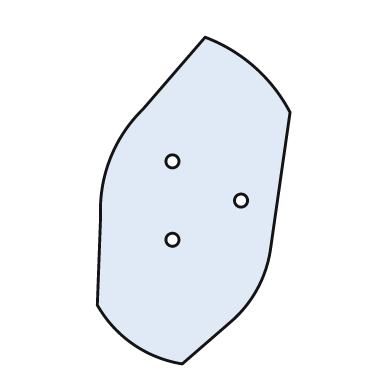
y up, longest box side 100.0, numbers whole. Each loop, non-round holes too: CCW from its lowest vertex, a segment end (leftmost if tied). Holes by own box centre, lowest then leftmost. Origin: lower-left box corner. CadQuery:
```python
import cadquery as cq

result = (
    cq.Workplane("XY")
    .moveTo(26.0, 0.0)
    .lineTo(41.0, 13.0)
    .threePointArc((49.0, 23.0), (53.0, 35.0))
    .lineTo(59.0, 77.0)
    .threePointArc((48.0, 91.0), (33.0, 100.0))
    .lineTo(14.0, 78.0)
    .threePointArc((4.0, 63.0), (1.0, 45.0))
    .lineTo(0.0, 18.0)
    .threePointArc((11.0, 6.0), (26.0, 0.0))
    .close()
    .moveTo(23.0, 38.0)
    .circle(2.0)
    .moveTo(44.0, 50.0)
    .circle(2.0)
    .moveTo(23.0, 62.0)
    .circle(2.0)
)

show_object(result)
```